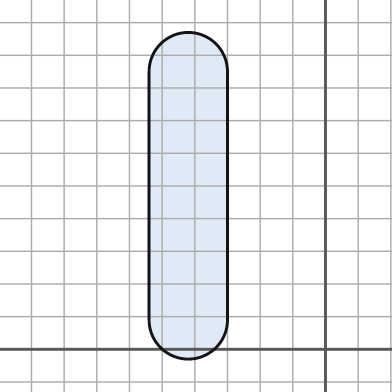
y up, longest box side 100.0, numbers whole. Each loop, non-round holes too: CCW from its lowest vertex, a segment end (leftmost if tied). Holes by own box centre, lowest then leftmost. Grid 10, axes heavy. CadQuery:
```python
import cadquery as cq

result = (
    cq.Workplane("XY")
    .moveTo(-54.0, 9.0)
    .threePointArc((-42.0, -3.0), (-30.0, 9.0))
    .lineTo(-30.0, 85.0)
    .threePointArc((-42.0, 97.0), (-54.0, 85.0))
    .close()
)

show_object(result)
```